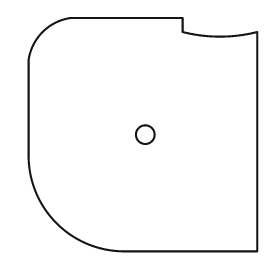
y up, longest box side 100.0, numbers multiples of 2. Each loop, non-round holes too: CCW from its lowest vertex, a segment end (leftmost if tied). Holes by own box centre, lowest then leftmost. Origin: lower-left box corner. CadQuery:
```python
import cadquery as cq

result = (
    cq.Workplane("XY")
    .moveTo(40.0, 0.0)
    .lineTo(98.0, 0.0)
    .lineTo(98.0, 94.0)
    .threePointArc((82.0, 92.0), (66.0, 94.0))
    .lineTo(66.0, 100.0)
    .lineTo(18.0, 100.0)
    .threePointArc((6.0, 94.0), (0.0, 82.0))
    .lineTo(0.0, 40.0)
    .threePointArc((12.0, 12.0), (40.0, 0.0))
    .close()
    .moveTo(50.0, 50.0)
    .circle(4.0)
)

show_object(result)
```